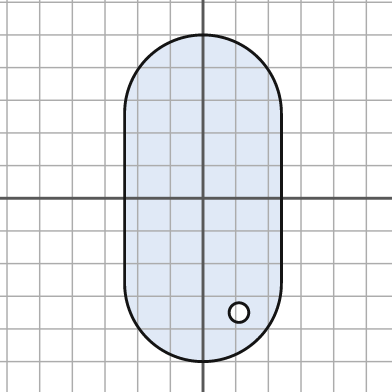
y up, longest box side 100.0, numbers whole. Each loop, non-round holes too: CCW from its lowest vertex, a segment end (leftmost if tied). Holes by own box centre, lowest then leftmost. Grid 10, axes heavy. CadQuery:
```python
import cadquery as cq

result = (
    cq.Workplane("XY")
    .moveTo(-24.0, -26.0)
    .threePointArc((0.0, -50.0), (24.0, -26.0))
    .lineTo(24.0, 26.0)
    .threePointArc((0.0, 50.0), (-24.0, 26.0))
    .close()
    .moveTo(11.0, -35.0)
    .circle(3.0)
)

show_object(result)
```